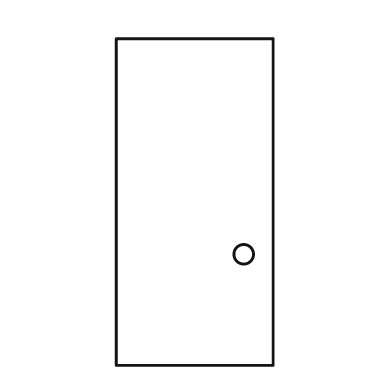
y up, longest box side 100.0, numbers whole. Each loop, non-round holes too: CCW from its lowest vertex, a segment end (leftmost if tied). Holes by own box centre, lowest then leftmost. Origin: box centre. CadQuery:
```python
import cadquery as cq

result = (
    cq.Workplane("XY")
    .moveTo(-24.0, -50.0)
    .lineTo(24.0, -50.0)
    .lineTo(24.0, 50.0)
    .lineTo(-24.0, 50.0)
    .close()
    .moveTo(15.0, -16.0)
    .circle(3.0)
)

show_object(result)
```